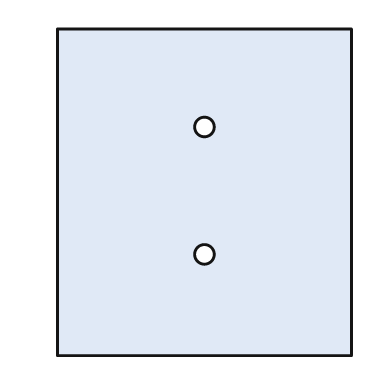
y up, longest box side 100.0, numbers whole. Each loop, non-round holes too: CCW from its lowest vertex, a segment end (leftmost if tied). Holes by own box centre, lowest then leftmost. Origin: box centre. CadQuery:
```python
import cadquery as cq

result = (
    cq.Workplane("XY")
    .moveTo(-45.0, -50.0)
    .lineTo(45.0, -50.0)
    .lineTo(45.0, 50.0)
    .lineTo(-45.0, 50.0)
    .close()
    .moveTo(0.0, -19.0)
    .circle(3.0)
    .moveTo(0.0, 20.0)
    .circle(3.0)
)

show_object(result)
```